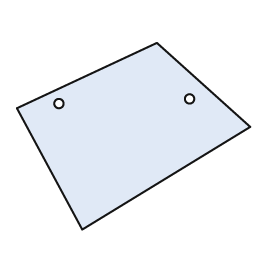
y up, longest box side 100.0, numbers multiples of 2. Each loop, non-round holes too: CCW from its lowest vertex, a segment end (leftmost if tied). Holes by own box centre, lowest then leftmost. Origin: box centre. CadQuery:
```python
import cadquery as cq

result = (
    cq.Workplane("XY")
    .moveTo(-22.0, -40.0)
    .lineTo(50.0, 4.0)
    .lineTo(10.0, 40.0)
    .lineTo(-50.0, 12.0)
    .close()
    .moveTo(-32.0, 14.0)
    .circle(2.0)
    .moveTo(24.0, 16.0)
    .circle(2.0)
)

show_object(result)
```